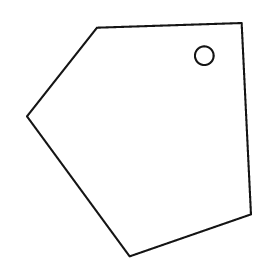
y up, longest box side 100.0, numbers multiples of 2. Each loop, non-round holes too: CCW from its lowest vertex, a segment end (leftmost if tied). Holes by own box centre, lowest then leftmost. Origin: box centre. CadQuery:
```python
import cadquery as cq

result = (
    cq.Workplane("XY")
    .moveTo(-4.0, -50.0)
    .lineTo(48.0, -32.0)
    .lineTo(44.0, 50.0)
    .lineTo(-18.0, 48.0)
    .lineTo(-48.0, 10.0)
    .close()
    .moveTo(28.0, 36.0)
    .circle(4.0)
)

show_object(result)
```